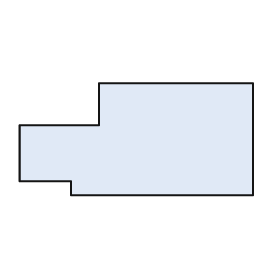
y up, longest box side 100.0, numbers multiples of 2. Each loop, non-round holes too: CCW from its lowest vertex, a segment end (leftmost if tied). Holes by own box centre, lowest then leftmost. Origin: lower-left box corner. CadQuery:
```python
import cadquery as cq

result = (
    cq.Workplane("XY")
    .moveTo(22.0, 0.0)
    .lineTo(100.0, 0.0)
    .lineTo(100.0, 48.0)
    .lineTo(34.0, 48.0)
    .lineTo(34.0, 30.0)
    .lineTo(0.0, 30.0)
    .lineTo(0.0, 6.0)
    .lineTo(22.0, 6.0)
    .close()
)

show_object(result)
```